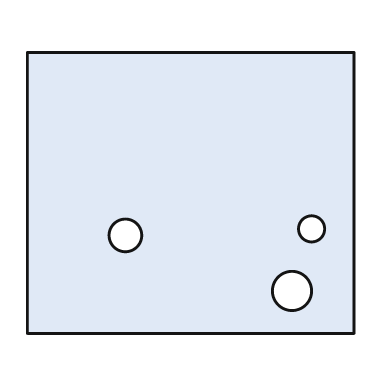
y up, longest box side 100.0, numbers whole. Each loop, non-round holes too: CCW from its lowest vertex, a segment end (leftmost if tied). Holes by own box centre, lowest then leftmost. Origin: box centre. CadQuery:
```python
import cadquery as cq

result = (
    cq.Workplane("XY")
    .moveTo(-50.0, -43.0)
    .lineTo(50.0, -43.0)
    .lineTo(50.0, 43.0)
    .lineTo(-50.0, 43.0)
    .close()
    .moveTo(31.0, -30.0)
    .circle(6.0)
    .moveTo(-20.0, -13.0)
    .circle(5.0)
    .moveTo(37.0, -11.0)
    .circle(4.0)
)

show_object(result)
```